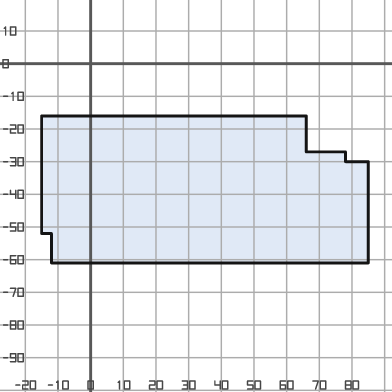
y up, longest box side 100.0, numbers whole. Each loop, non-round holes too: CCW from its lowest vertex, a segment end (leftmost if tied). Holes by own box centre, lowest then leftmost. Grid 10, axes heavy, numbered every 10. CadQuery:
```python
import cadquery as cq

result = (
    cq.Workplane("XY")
    .moveTo(-12.0, -61.0)
    .lineTo(85.0, -61.0)
    .lineTo(85.0, -30.0)
    .lineTo(78.0, -30.0)
    .lineTo(78.0, -27.0)
    .lineTo(66.0, -27.0)
    .lineTo(66.0, -16.0)
    .lineTo(-15.0, -16.0)
    .lineTo(-15.0, -52.0)
    .lineTo(-12.0, -52.0)
    .close()
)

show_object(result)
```